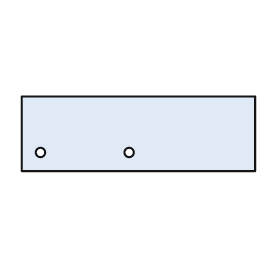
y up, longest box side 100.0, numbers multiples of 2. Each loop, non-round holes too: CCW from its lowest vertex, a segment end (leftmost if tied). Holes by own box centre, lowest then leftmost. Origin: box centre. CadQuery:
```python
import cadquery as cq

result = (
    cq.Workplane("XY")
    .moveTo(-50.0, -16.0)
    .lineTo(50.0, -16.0)
    .lineTo(50.0, 16.0)
    .lineTo(-50.0, 16.0)
    .close()
    .moveTo(-42.0, -8.0)
    .circle(2.0)
    .moveTo(-4.0, -8.0)
    .circle(2.0)
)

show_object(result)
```